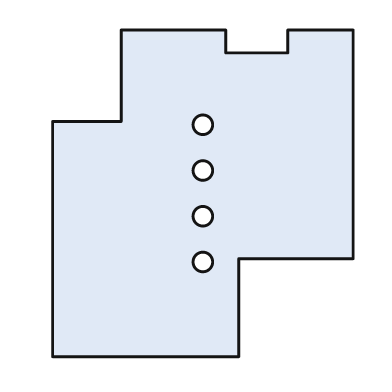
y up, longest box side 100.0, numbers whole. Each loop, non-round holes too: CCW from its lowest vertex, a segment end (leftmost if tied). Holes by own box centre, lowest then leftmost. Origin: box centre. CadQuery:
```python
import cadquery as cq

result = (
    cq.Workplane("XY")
    .moveTo(-46.0, -50.0)
    .lineTo(11.0, -50.0)
    .lineTo(11.0, -20.0)
    .lineTo(46.0, -20.0)
    .lineTo(46.0, 50.0)
    .lineTo(26.0, 50.0)
    .lineTo(26.0, 43.0)
    .lineTo(7.0, 43.0)
    .lineTo(7.0, 50.0)
    .lineTo(-25.0, 50.0)
    .lineTo(-25.0, 22.0)
    .lineTo(-46.0, 22.0)
    .close()
    .moveTo(0.0, -21.0)
    .circle(3.0)
    .moveTo(0.0, -7.0)
    .circle(3.0)
    .moveTo(0.0, 7.0)
    .circle(3.0)
    .moveTo(0.0, 21.0)
    .circle(3.0)
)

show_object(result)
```